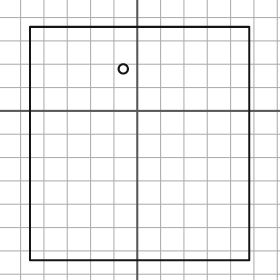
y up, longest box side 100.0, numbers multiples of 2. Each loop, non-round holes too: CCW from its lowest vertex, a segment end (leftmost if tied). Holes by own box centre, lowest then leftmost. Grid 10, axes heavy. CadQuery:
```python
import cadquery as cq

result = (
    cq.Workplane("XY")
    .moveTo(-46.0, -64.0)
    .lineTo(48.0, -64.0)
    .lineTo(48.0, 36.0)
    .lineTo(-46.0, 36.0)
    .close()
    .moveTo(-6.0, 18.0)
    .circle(2.0)
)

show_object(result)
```